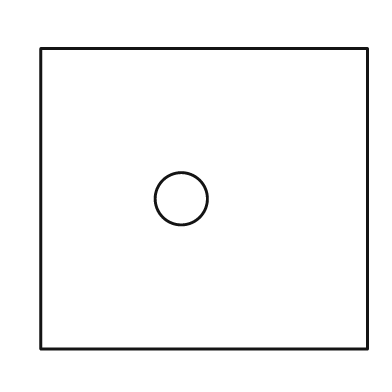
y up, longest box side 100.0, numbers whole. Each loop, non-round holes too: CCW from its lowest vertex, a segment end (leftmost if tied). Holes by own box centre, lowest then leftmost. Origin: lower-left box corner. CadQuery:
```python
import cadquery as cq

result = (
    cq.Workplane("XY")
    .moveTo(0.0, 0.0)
    .lineTo(100.0, 0.0)
    .lineTo(100.0, 92.0)
    .lineTo(0.0, 92.0)
    .close()
    .moveTo(43.0, 46.0)
    .circle(8.0)
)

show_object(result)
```